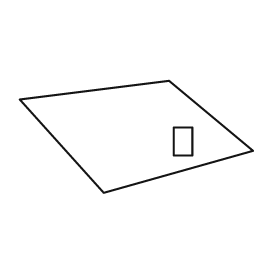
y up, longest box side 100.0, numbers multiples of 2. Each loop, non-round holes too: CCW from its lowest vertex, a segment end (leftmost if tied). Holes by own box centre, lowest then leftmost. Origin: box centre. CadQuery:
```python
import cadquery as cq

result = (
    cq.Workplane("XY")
    .moveTo(-14.0, -24.0)
    .lineTo(50.0, -6.0)
    .lineTo(14.0, 24.0)
    .lineTo(-50.0, 16.0)
    .close()
    .moveTo(16.0, -8.0)
    .lineTo(24.0, -8.0)
    .lineTo(24.0, 4.0)
    .lineTo(16.0, 4.0)
    .close()
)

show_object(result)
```